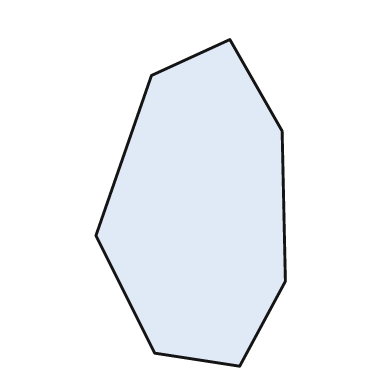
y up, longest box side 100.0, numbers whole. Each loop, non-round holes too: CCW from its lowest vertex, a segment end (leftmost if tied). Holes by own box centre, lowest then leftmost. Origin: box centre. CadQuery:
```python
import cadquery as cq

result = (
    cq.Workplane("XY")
    .moveTo(15.0, -50.0)
    .lineTo(29.0, -24.0)
    .lineTo(28.0, 22.0)
    .lineTo(12.0, 50.0)
    .lineTo(-12.0, 39.0)
    .lineTo(-29.0, -10.0)
    .lineTo(-11.0, -46.0)
    .close()
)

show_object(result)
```